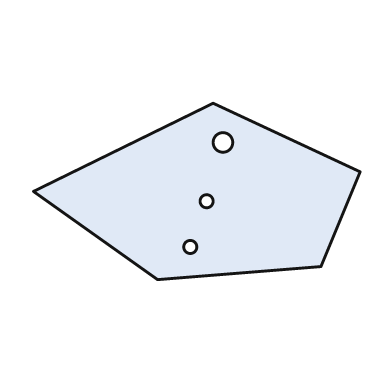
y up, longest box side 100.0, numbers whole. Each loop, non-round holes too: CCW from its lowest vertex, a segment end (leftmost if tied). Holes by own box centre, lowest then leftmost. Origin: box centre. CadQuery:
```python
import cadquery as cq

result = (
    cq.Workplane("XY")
    .moveTo(-12.0, -27.0)
    .lineTo(38.0, -23.0)
    .lineTo(50.0, 6.0)
    .lineTo(5.0, 27.0)
    .lineTo(-50.0, 0.0)
    .close()
    .moveTo(-2.0, -17.0)
    .circle(2.0)
    .moveTo(3.0, -3.0)
    .circle(2.0)
    .moveTo(8.0, 15.0)
    .circle(3.0)
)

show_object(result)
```